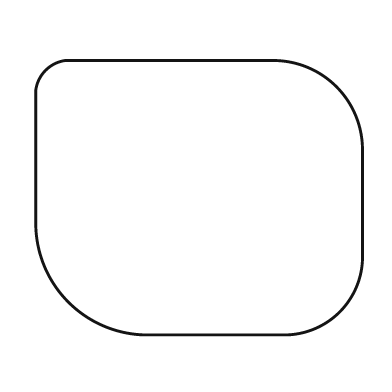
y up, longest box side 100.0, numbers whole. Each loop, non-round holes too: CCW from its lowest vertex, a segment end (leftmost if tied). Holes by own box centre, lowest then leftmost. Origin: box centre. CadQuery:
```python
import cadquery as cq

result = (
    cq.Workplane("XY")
    .moveTo(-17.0, -42.0)
    .lineTo(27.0, -42.0)
    .threePointArc((43.0, -35.0), (50.0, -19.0))
    .lineTo(50.0, 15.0)
    .threePointArc((42.0, 34.0), (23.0, 42.0))
    .lineTo(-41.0, 42.0)
    .threePointArc((-47.0, 39.0), (-50.0, 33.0))
    .lineTo(-50.0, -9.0)
    .threePointArc((-40.0, -32.0), (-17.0, -42.0))
    .close()
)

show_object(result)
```